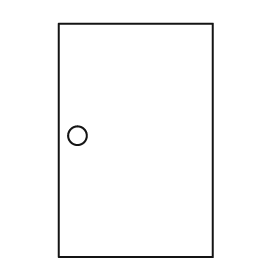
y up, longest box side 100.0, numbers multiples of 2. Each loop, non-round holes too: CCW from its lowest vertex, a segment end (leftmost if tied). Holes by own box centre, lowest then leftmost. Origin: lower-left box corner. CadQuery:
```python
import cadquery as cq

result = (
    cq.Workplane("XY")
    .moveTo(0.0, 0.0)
    .lineTo(66.0, 0.0)
    .lineTo(66.0, 100.0)
    .lineTo(0.0, 100.0)
    .close()
    .moveTo(8.0, 52.0)
    .circle(4.0)
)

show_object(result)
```